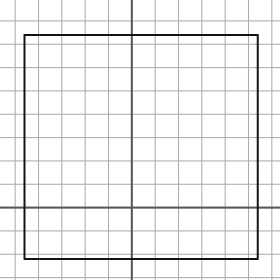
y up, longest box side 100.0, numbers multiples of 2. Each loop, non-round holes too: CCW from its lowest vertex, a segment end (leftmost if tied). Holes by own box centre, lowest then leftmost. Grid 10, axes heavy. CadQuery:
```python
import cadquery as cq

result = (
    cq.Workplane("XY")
    .moveTo(-46.0, -22.0)
    .lineTo(54.0, -22.0)
    .lineTo(54.0, 74.0)
    .lineTo(-46.0, 74.0)
    .close()
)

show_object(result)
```